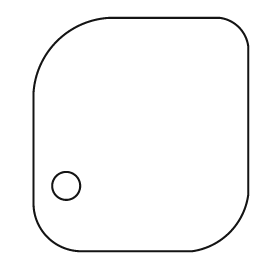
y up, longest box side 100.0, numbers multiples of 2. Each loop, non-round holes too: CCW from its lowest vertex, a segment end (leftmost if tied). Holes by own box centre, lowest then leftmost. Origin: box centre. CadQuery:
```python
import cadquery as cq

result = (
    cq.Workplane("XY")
    .moveTo(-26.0, -50.0)
    .lineTo(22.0, -50.0)
    .threePointArc((38.0, -42.0), (46.0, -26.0))
    .lineTo(46.0, 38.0)
    .threePointArc((42.0, 46.0), (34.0, 50.0))
    .lineTo(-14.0, 50.0)
    .threePointArc((-36.0, 40.0), (-46.0, 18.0))
    .lineTo(-46.0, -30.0)
    .threePointArc((-40.0, -44.0), (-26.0, -50.0))
    .close()
    .moveTo(-32.0, -22.0)
    .circle(6.0)
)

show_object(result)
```